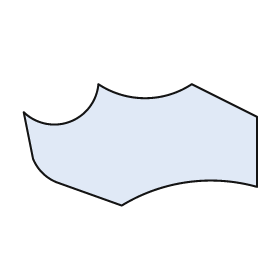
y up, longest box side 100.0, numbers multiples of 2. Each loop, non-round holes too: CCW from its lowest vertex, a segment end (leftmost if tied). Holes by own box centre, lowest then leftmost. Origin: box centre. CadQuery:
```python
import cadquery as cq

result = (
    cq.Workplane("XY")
    .moveTo(-8.0, -26.0)
    .threePointArc((20.0, -16.0), (50.0, -18.0))
    .lineTo(50.0, 12.0)
    .lineTo(22.0, 26.0)
    .threePointArc((2.0, 20.0), (-18.0, 26.0))
    .threePointArc((-30.0, 10.0), (-50.0, 14.0))
    .lineTo(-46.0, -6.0)
    .threePointArc((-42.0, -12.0), (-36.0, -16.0))
    .close()
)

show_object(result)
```